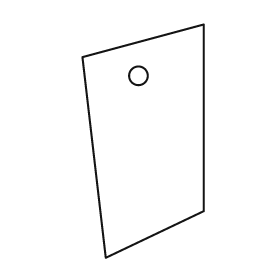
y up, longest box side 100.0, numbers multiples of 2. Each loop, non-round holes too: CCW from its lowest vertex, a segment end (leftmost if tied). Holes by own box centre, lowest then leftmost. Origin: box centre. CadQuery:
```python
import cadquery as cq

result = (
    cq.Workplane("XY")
    .moveTo(-16.0, -50.0)
    .lineTo(26.0, -30.0)
    .lineTo(26.0, 50.0)
    .lineTo(-26.0, 36.0)
    .close()
    .moveTo(-2.0, 28.0)
    .circle(4.0)
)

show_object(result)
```